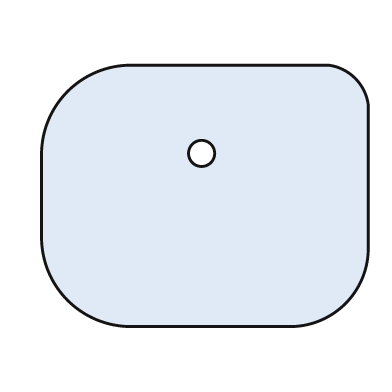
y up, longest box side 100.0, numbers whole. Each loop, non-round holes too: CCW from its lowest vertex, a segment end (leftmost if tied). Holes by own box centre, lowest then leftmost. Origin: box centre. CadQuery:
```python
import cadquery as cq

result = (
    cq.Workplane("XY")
    .moveTo(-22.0, -40.0)
    .lineTo(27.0, -40.0)
    .threePointArc((43.0, -33.0), (50.0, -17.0))
    .lineTo(50.0, 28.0)
    .threePointArc((46.0, 36.0), (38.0, 40.0))
    .lineTo(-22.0, 40.0)
    .threePointArc((-42.0, 32.0), (-50.0, 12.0))
    .lineTo(-50.0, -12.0)
    .threePointArc((-42.0, -32.0), (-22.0, -40.0))
    .close()
    .moveTo(-1.0, 13.0)
    .circle(4.0)
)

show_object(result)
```